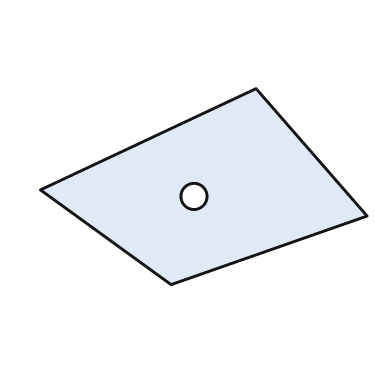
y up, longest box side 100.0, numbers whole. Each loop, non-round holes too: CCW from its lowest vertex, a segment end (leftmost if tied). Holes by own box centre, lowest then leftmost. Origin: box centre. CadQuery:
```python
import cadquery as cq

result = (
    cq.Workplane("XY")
    .moveTo(-10.0, -30.0)
    .lineTo(50.0, -9.0)
    .lineTo(16.0, 30.0)
    .lineTo(-50.0, -1.0)
    .close()
    .moveTo(-3.0, -3.0)
    .circle(4.0)
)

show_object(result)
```